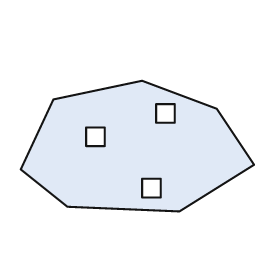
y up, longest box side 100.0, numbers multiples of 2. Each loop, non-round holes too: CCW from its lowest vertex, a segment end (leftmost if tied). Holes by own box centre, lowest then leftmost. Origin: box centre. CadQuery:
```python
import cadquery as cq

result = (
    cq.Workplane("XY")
    .moveTo(18.0, -28.0)
    .lineTo(50.0, -8.0)
    .lineTo(34.0, 16.0)
    .lineTo(2.0, 28.0)
    .lineTo(-36.0, 20.0)
    .lineTo(-50.0, -10.0)
    .lineTo(-30.0, -26.0)
    .close()
    .moveTo(2.0, -22.0)
    .lineTo(10.0, -22.0)
    .lineTo(10.0, -14.0)
    .lineTo(2.0, -14.0)
    .close()
    .moveTo(-22.0, 0.0)
    .lineTo(-14.0, 0.0)
    .lineTo(-14.0, 8.0)
    .lineTo(-22.0, 8.0)
    .close()
    .moveTo(8.0, 10.0)
    .lineTo(16.0, 10.0)
    .lineTo(16.0, 18.0)
    .lineTo(8.0, 18.0)
    .close()
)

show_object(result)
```